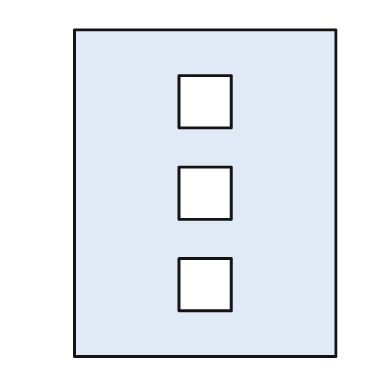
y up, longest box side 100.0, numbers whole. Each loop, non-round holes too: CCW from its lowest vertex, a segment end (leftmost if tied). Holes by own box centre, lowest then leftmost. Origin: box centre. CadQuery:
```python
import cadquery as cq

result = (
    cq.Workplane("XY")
    .moveTo(-40.0, -50.0)
    .lineTo(40.0, -50.0)
    .lineTo(40.0, 50.0)
    .lineTo(-40.0, 50.0)
    .close()
    .moveTo(-8.0, -36.0)
    .lineTo(8.0, -36.0)
    .lineTo(8.0, -20.0)
    .lineTo(-8.0, -20.0)
    .close()
    .moveTo(-8.0, -8.0)
    .lineTo(8.0, -8.0)
    .lineTo(8.0, 8.0)
    .lineTo(-8.0, 8.0)
    .close()
    .moveTo(-8.0, 20.0)
    .lineTo(8.0, 20.0)
    .lineTo(8.0, 36.0)
    .lineTo(-8.0, 36.0)
    .close()
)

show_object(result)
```